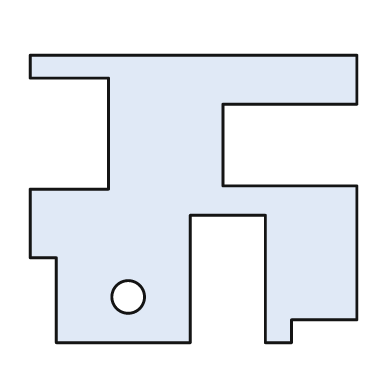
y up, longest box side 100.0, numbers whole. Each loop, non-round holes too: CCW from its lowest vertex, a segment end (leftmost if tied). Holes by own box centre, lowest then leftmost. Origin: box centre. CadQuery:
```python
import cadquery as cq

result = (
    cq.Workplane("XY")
    .moveTo(-42.0, -44.0)
    .lineTo(-1.0, -44.0)
    .lineTo(-1.0, -5.0)
    .lineTo(22.0, -5.0)
    .lineTo(22.0, -44.0)
    .lineTo(30.0, -44.0)
    .lineTo(30.0, -37.0)
    .lineTo(50.0, -37.0)
    .lineTo(50.0, 4.0)
    .lineTo(9.0, 4.0)
    .lineTo(9.0, 29.0)
    .lineTo(50.0, 29.0)
    .lineTo(50.0, 44.0)
    .lineTo(-50.0, 44.0)
    .lineTo(-50.0, 37.0)
    .lineTo(-26.0, 37.0)
    .lineTo(-26.0, 3.0)
    .lineTo(-50.0, 3.0)
    .lineTo(-50.0, -18.0)
    .lineTo(-42.0, -18.0)
    .close()
    .moveTo(-20.0, -30.0)
    .circle(5.0)
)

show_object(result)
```